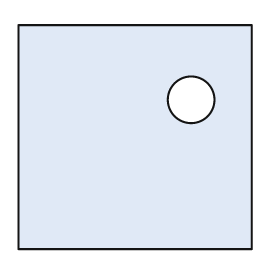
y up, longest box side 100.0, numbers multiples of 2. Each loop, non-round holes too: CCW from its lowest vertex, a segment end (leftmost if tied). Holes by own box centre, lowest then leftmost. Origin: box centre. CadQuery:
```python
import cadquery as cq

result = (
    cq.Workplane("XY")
    .moveTo(-50.0, -48.0)
    .lineTo(50.0, -48.0)
    .lineTo(50.0, 48.0)
    .lineTo(-50.0, 48.0)
    .close()
    .moveTo(24.0, 16.0)
    .circle(10.0)
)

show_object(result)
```